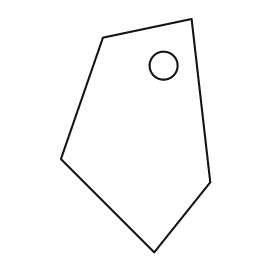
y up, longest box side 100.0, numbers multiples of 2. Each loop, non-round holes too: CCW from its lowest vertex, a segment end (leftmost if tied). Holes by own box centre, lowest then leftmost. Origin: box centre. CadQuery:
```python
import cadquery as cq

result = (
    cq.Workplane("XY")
    .moveTo(8.0, -50.0)
    .lineTo(32.0, -20.0)
    .lineTo(24.0, 50.0)
    .lineTo(-14.0, 42.0)
    .lineTo(-32.0, -10.0)
    .close()
    .moveTo(12.0, 30.0)
    .circle(6.0)
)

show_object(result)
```